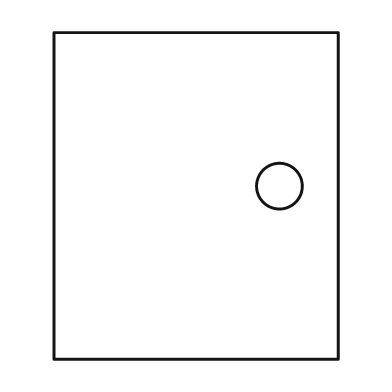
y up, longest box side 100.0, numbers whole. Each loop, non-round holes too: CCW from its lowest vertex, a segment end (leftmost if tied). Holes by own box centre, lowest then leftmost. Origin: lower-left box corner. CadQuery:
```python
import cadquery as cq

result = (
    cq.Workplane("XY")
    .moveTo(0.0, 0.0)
    .lineTo(87.0, 0.0)
    .lineTo(87.0, 100.0)
    .lineTo(0.0, 100.0)
    .close()
    .moveTo(69.0, 53.0)
    .circle(7.0)
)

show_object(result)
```